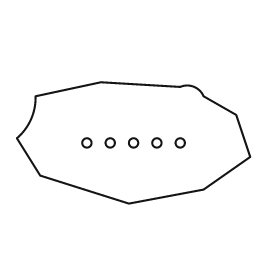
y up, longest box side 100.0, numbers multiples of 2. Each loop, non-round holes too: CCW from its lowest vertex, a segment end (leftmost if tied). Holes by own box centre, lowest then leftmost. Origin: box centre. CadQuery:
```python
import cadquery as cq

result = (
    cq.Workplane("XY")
    .moveTo(-2.0, -26.0)
    .lineTo(30.0, -20.0)
    .lineTo(50.0, -6.0)
    .lineTo(44.0, 12.0)
    .lineTo(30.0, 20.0)
    .threePointArc((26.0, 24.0), (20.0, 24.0))
    .lineTo(-14.0, 26.0)
    .lineTo(-42.0, 20.0)
    .threePointArc((-44.0, 10.0), (-50.0, 2.0))
    .lineTo(-40.0, -14.0)
    .close()
    .moveTo(-20.0, 0.0)
    .circle(2.0)
    .moveTo(-10.0, 0.0)
    .circle(2.0)
    .moveTo(0.0, 0.0)
    .circle(2.0)
    .moveTo(10.0, 0.0)
    .circle(2.0)
    .moveTo(20.0, 0.0)
    .circle(2.0)
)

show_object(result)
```